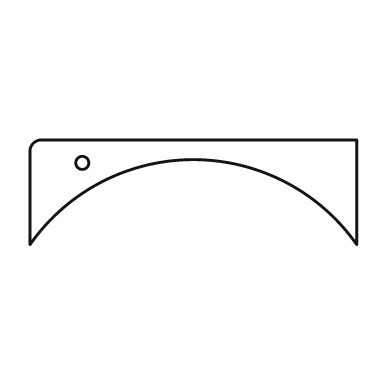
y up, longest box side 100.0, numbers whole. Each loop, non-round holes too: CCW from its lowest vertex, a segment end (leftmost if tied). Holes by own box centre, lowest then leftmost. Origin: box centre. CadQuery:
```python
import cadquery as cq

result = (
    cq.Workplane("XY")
    .moveTo(-50.0, -16.0)
    .threePointArc((0.0, 10.0), (50.0, -16.0))
    .lineTo(50.0, 16.0)
    .lineTo(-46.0, 16.0)
    .threePointArc((-49.0, 15.0), (-50.0, 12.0))
    .close()
    .moveTo(-34.0, 9.0)
    .circle(2.0)
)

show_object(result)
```